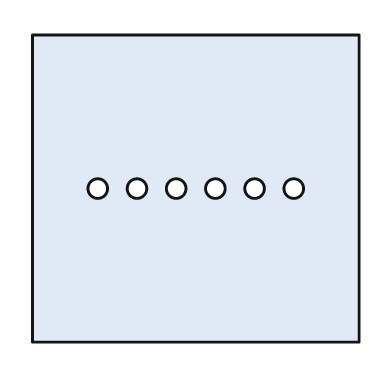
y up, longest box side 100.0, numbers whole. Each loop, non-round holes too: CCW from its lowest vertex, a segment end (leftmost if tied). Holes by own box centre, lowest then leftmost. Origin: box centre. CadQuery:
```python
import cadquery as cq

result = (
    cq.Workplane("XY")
    .moveTo(-50.0, -47.0)
    .lineTo(50.0, -47.0)
    .lineTo(50.0, 47.0)
    .lineTo(-50.0, 47.0)
    .close()
    .moveTo(-30.0, 0.0)
    .circle(3.0)
    .moveTo(-18.0, 0.0)
    .circle(3.0)
    .moveTo(-6.0, 0.0)
    .circle(3.0)
    .moveTo(6.0, 0.0)
    .circle(3.0)
    .moveTo(18.0, 0.0)
    .circle(3.0)
    .moveTo(30.0, 0.0)
    .circle(3.0)
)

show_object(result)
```